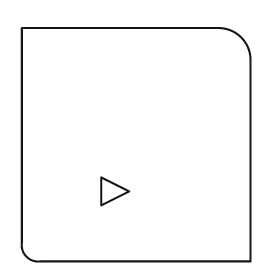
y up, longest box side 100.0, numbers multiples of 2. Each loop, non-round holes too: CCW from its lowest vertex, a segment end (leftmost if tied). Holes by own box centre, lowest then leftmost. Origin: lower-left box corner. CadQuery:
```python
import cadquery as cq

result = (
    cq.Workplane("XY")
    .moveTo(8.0, 0.0)
    .lineTo(98.0, 0.0)
    .lineTo(98.0, 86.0)
    .threePointArc((94.0, 96.0), (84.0, 100.0))
    .lineTo(0.0, 100.0)
    .lineTo(0.0, 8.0)
    .threePointArc((2.0, 2.0), (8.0, 0.0))
    .close()
    .moveTo(34.0, 24.0)
    .lineTo(46.0, 30.0)
    .lineTo(34.0, 36.0)
    .close()
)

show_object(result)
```